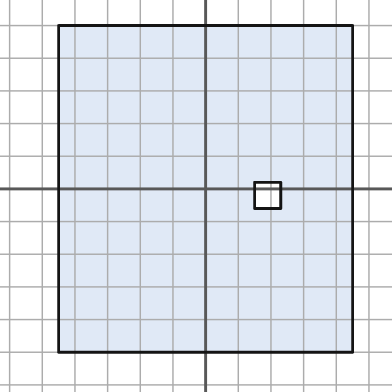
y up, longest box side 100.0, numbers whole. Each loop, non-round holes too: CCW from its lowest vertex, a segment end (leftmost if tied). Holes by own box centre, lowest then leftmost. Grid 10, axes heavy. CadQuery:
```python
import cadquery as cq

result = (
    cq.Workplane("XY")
    .moveTo(-45.0, -50.0)
    .lineTo(45.0, -50.0)
    .lineTo(45.0, 50.0)
    .lineTo(-45.0, 50.0)
    .close()
    .moveTo(15.0, -6.0)
    .lineTo(23.0, -6.0)
    .lineTo(23.0, 2.0)
    .lineTo(15.0, 2.0)
    .close()
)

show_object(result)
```